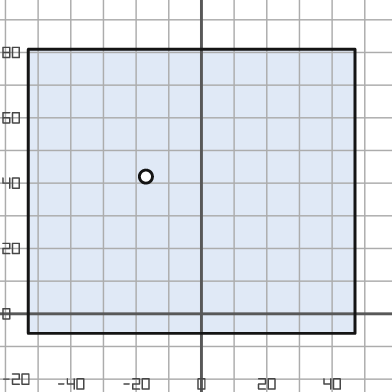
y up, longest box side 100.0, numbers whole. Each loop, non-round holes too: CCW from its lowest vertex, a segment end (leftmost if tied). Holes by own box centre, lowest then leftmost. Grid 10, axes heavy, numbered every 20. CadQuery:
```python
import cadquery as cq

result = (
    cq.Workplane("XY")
    .moveTo(-53.0, -6.0)
    .lineTo(47.0, -6.0)
    .lineTo(47.0, 81.0)
    .lineTo(-53.0, 81.0)
    .close()
    .moveTo(-17.0, 42.0)
    .circle(2.0)
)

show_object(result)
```